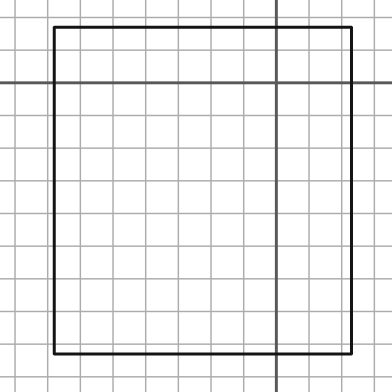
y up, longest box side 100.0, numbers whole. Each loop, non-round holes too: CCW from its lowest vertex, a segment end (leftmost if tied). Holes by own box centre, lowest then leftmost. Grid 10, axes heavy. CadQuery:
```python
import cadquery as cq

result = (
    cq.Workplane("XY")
    .moveTo(-68.0, -83.0)
    .lineTo(23.0, -83.0)
    .lineTo(23.0, 17.0)
    .lineTo(-68.0, 17.0)
    .close()
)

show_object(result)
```